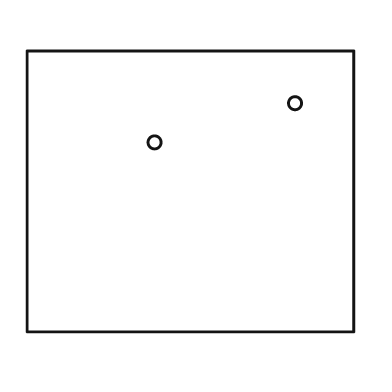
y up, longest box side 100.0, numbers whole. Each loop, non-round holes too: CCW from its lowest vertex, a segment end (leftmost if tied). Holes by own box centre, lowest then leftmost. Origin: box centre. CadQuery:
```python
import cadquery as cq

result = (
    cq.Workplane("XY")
    .moveTo(-50.0, -43.0)
    .lineTo(50.0, -43.0)
    .lineTo(50.0, 43.0)
    .lineTo(-50.0, 43.0)
    .close()
    .moveTo(-11.0, 15.0)
    .circle(2.0)
    .moveTo(32.0, 27.0)
    .circle(2.0)
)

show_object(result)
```